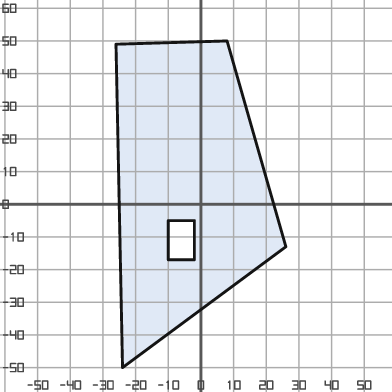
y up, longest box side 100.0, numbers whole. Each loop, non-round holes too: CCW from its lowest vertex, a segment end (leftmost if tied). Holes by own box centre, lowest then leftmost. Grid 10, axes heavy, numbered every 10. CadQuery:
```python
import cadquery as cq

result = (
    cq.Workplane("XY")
    .moveTo(-24.0, -50.0)
    .lineTo(26.0, -13.0)
    .lineTo(8.0, 50.0)
    .lineTo(-26.0, 49.0)
    .close()
    .moveTo(-10.0, -17.0)
    .lineTo(-2.0, -17.0)
    .lineTo(-2.0, -5.0)
    .lineTo(-10.0, -5.0)
    .close()
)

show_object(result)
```